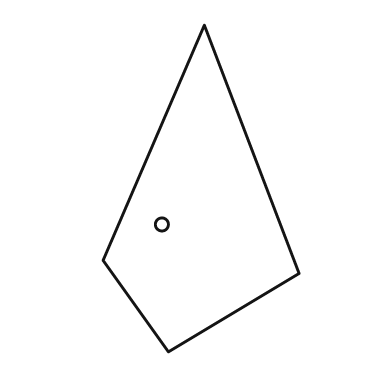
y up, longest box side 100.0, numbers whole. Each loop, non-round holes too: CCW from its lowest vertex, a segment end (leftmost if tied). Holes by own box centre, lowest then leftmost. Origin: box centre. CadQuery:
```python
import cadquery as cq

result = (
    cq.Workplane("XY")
    .moveTo(-10.0, -50.0)
    .lineTo(30.0, -26.0)
    .lineTo(1.0, 50.0)
    .lineTo(-30.0, -22.0)
    .close()
    .moveTo(-12.0, -11.0)
    .circle(2.0)
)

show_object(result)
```